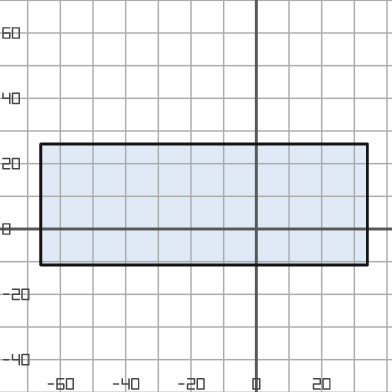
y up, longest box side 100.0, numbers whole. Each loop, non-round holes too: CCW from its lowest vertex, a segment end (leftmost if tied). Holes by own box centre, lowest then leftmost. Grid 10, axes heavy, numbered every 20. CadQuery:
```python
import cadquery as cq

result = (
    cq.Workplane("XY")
    .moveTo(-66.0, -11.0)
    .lineTo(34.0, -11.0)
    .lineTo(34.0, 26.0)
    .lineTo(-66.0, 26.0)
    .close()
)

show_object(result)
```